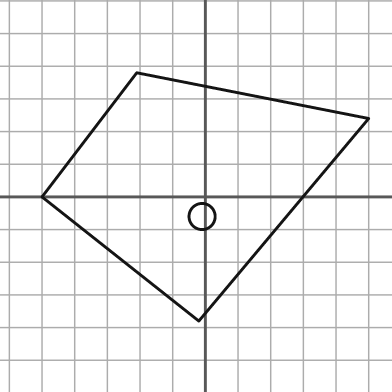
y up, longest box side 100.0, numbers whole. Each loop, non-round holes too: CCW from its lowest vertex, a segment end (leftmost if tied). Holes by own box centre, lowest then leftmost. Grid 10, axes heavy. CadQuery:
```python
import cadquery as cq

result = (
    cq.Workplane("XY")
    .moveTo(-2.0, -38.0)
    .lineTo(50.0, 24.0)
    .lineTo(-21.0, 38.0)
    .lineTo(-50.0, 0.0)
    .close()
    .moveTo(-1.0, -6.0)
    .circle(4.0)
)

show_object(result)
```